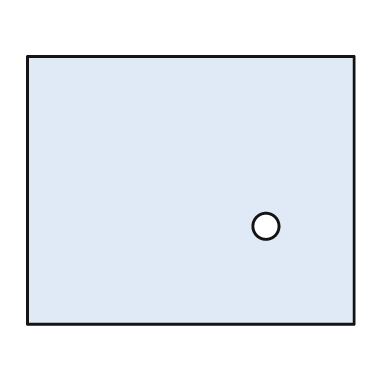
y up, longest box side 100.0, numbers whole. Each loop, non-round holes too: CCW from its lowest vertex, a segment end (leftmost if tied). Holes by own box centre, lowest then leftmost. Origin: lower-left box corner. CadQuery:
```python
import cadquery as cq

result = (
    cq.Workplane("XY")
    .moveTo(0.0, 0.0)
    .lineTo(100.0, 0.0)
    .lineTo(100.0, 82.0)
    .lineTo(0.0, 82.0)
    .close()
    .moveTo(73.0, 30.0)
    .circle(4.0)
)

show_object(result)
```